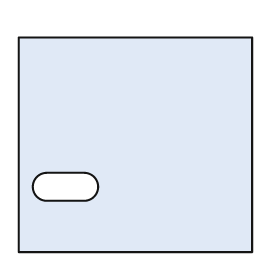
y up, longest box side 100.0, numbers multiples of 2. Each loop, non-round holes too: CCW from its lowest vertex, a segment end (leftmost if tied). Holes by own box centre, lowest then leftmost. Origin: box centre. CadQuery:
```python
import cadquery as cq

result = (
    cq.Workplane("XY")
    .moveTo(-50.0, -46.0)
    .lineTo(50.0, -46.0)
    .lineTo(50.0, 46.0)
    .lineTo(-50.0, 46.0)
    .close()
    .moveTo(-38.0, -24.0)
    .lineTo(-22.0, -24.0)
    .threePointArc((-16.0, -18.0), (-22.0, -12.0))
    .lineTo(-38.0, -12.0)
    .threePointArc((-44.0, -18.0), (-38.0, -24.0))
    .close()
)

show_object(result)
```